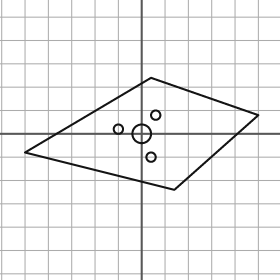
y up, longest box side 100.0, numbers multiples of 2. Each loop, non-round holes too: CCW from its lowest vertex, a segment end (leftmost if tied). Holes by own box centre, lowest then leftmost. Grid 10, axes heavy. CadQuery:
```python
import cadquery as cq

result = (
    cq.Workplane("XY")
    .moveTo(14.0, -24.0)
    .lineTo(50.0, 8.0)
    .lineTo(4.0, 24.0)
    .lineTo(-50.0, -8.0)
    .close()
    .moveTo(4.0, -10.0)
    .circle(2.0)
    .moveTo(0.0, 0.0)
    .circle(4.0)
    .moveTo(-10.0, 2.0)
    .circle(2.0)
    .moveTo(6.0, 8.0)
    .circle(2.0)
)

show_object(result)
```